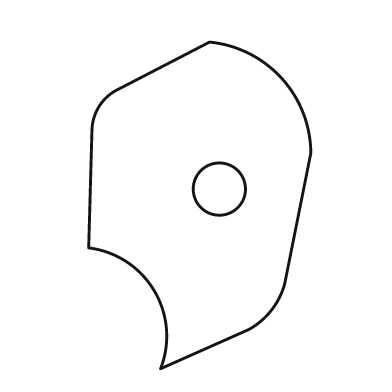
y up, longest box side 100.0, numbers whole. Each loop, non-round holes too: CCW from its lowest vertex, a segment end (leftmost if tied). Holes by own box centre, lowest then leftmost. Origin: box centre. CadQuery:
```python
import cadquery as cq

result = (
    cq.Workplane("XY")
    .moveTo(-12.0, -50.0)
    .lineTo(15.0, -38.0)
    .threePointArc((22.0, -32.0), (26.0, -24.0))
    .lineTo(34.0, 16.0)
    .threePointArc((25.0, 39.0), (3.0, 50.0))
    .lineTo(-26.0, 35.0)
    .threePointArc((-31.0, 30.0), (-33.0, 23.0))
    .lineTo(-34.0, -13.0)
    .threePointArc((-14.0, -26.0), (-12.0, -50.0))
    .close()
    .moveTo(6.0, 5.0)
    .circle(8.0)
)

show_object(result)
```